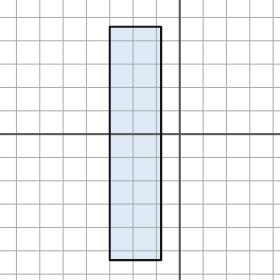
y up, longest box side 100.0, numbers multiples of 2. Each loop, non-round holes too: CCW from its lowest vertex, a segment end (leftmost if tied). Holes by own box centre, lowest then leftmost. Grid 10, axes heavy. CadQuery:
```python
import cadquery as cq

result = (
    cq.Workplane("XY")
    .moveTo(-30.0, -54.0)
    .lineTo(-8.0, -54.0)
    .lineTo(-8.0, 46.0)
    .lineTo(-30.0, 46.0)
    .close()
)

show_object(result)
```